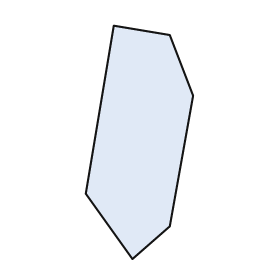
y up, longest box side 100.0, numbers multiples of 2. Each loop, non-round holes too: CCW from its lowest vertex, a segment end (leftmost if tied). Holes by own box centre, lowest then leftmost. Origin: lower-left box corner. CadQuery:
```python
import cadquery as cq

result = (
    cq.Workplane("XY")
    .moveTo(20.0, 0.0)
    .lineTo(36.0, 14.0)
    .lineTo(46.0, 70.0)
    .lineTo(36.0, 96.0)
    .lineTo(12.0, 100.0)
    .lineTo(0.0, 28.0)
    .close()
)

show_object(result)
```